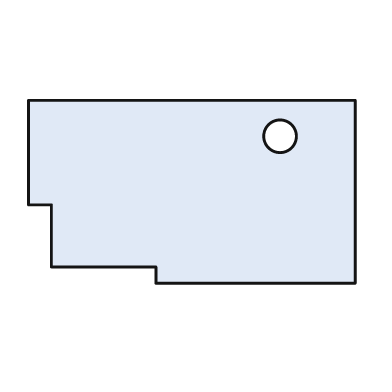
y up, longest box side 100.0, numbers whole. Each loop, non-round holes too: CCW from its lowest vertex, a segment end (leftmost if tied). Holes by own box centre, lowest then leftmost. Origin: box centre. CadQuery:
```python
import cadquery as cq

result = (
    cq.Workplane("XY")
    .moveTo(-11.0, -28.0)
    .lineTo(50.0, -28.0)
    .lineTo(50.0, 28.0)
    .lineTo(-50.0, 28.0)
    .lineTo(-50.0, -4.0)
    .lineTo(-43.0, -4.0)
    .lineTo(-43.0, -23.0)
    .lineTo(-11.0, -23.0)
    .close()
    .moveTo(27.0, 17.0)
    .circle(5.0)
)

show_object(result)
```